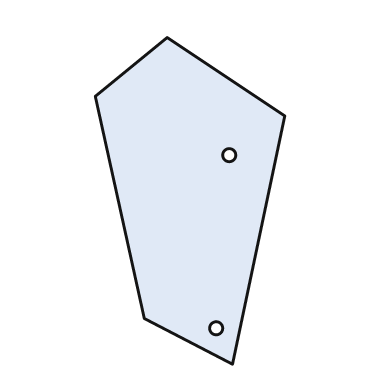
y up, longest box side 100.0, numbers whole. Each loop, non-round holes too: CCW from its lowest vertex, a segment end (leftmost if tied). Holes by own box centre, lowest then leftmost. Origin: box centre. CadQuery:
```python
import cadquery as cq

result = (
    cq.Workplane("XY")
    .moveTo(13.0, -50.0)
    .lineTo(29.0, 26.0)
    .lineTo(-7.0, 50.0)
    .lineTo(-29.0, 32.0)
    .lineTo(-14.0, -36.0)
    .close()
    .moveTo(8.0, -39.0)
    .circle(2.0)
    .moveTo(12.0, 14.0)
    .circle(2.0)
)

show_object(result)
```